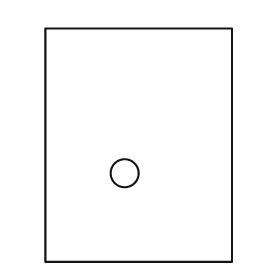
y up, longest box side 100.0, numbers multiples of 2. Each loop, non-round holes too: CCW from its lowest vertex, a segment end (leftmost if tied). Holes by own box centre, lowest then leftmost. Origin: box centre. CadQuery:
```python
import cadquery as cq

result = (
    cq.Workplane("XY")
    .moveTo(-40.0, -50.0)
    .lineTo(40.0, -50.0)
    .lineTo(40.0, 50.0)
    .lineTo(-40.0, 50.0)
    .close()
    .moveTo(-6.0, -12.0)
    .circle(6.0)
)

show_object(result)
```